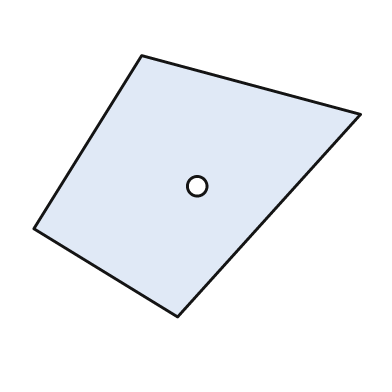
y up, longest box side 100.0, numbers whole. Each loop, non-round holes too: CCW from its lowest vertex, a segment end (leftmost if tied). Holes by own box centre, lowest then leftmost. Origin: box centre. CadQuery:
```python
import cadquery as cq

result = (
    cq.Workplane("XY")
    .moveTo(-6.0, -40.0)
    .lineTo(50.0, 22.0)
    .lineTo(-17.0, 40.0)
    .lineTo(-50.0, -13.0)
    .close()
    .moveTo(0.0, 0.0)
    .circle(3.0)
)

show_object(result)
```